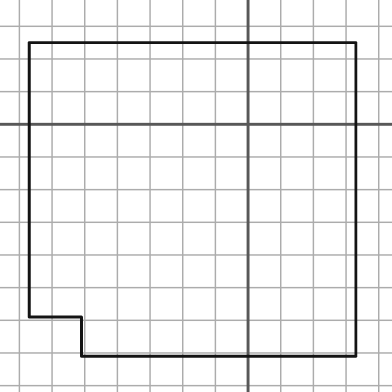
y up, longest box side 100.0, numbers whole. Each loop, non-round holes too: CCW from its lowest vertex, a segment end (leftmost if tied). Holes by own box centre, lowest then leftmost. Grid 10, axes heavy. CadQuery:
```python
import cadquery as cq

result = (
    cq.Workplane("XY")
    .moveTo(-51.0, -71.0)
    .lineTo(33.0, -71.0)
    .lineTo(33.0, 25.0)
    .lineTo(-67.0, 25.0)
    .lineTo(-67.0, -59.0)
    .lineTo(-51.0, -59.0)
    .close()
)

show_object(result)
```